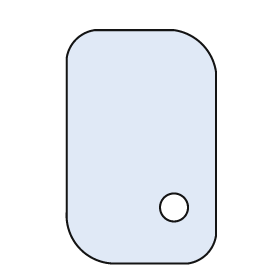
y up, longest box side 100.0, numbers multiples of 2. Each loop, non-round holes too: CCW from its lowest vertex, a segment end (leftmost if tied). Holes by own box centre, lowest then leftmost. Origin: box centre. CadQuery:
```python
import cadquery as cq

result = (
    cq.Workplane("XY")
    .moveTo(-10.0, -50.0)
    .lineTo(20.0, -50.0)
    .threePointArc((28.0, -46.0), (32.0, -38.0))
    .lineTo(32.0, 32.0)
    .threePointArc((26.0, 44.0), (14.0, 50.0))
    .lineTo(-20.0, 50.0)
    .threePointArc((-28.0, 46.0), (-32.0, 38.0))
    .lineTo(-32.0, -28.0)
    .threePointArc((-26.0, -44.0), (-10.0, -50.0))
    .close()
    .moveTo(14.0, -26.0)
    .circle(6.0)
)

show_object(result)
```